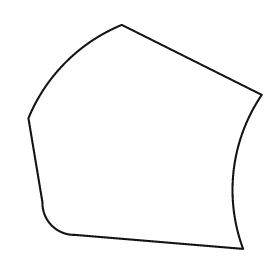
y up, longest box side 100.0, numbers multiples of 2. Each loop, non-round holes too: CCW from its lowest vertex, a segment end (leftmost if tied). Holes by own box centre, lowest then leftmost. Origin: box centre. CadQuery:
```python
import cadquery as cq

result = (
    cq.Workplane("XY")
    .moveTo(42.0, -48.0)
    .threePointArc((38.0, -14.0), (50.0, 18.0))
    .lineTo(-10.0, 48.0)
    .threePointArc((-34.0, 32.0), (-50.0, 8.0))
    .lineTo(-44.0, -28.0)
    .threePointArc((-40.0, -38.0), (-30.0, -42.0))
    .close()
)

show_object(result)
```